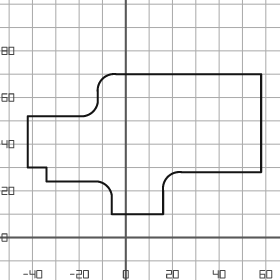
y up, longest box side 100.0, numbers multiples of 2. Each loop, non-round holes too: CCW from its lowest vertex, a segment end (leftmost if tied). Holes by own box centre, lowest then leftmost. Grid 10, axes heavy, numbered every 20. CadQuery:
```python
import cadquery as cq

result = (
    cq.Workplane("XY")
    .moveTo(-6.0, 10.0)
    .lineTo(16.0, 10.0)
    .lineTo(16.0, 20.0)
    .threePointArc((18.0, 26.0), (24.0, 28.0))
    .lineTo(58.0, 28.0)
    .lineTo(58.0, 70.0)
    .lineTo(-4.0, 70.0)
    .threePointArc((-10.0, 68.0), (-12.0, 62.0))
    .lineTo(-12.0, 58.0)
    .threePointArc((-14.0, 54.0), (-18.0, 52.0))
    .lineTo(-42.0, 52.0)
    .lineTo(-42.0, 30.0)
    .lineTo(-34.0, 30.0)
    .lineTo(-34.0, 24.0)
    .lineTo(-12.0, 24.0)
    .threePointArc((-8.0, 22.0), (-6.0, 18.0))
    .close()
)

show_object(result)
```